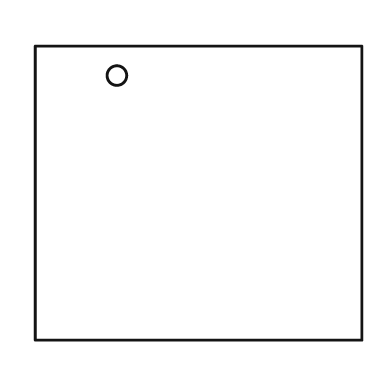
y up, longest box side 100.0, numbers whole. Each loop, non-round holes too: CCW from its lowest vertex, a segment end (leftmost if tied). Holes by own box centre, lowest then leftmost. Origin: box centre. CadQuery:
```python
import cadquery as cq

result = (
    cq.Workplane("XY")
    .moveTo(-50.0, -45.0)
    .lineTo(50.0, -45.0)
    .lineTo(50.0, 45.0)
    .lineTo(-50.0, 45.0)
    .close()
    .moveTo(-25.0, 36.0)
    .circle(3.0)
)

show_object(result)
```